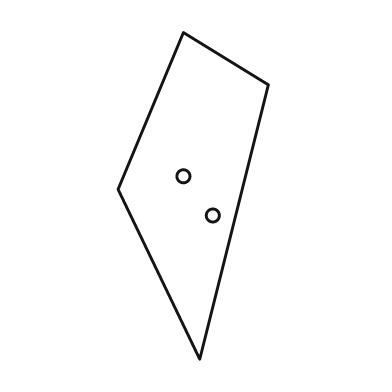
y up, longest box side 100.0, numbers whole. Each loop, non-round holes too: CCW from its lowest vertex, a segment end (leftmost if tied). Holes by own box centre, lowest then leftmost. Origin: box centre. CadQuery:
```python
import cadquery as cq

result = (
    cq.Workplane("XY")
    .moveTo(2.0, -50.0)
    .lineTo(23.0, 34.0)
    .lineTo(-3.0, 50.0)
    .lineTo(-23.0, 2.0)
    .close()
    .moveTo(6.0, -6.0)
    .circle(2.0)
    .moveTo(-3.0, 6.0)
    .circle(2.0)
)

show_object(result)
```